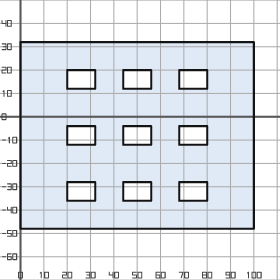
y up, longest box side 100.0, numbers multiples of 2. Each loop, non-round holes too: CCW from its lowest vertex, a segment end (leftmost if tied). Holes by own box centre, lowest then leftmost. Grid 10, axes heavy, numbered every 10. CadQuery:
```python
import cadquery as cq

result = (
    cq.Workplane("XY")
    .moveTo(0.0, -48.0)
    .lineTo(100.0, -48.0)
    .lineTo(100.0, 32.0)
    .lineTo(0.0, 32.0)
    .close()
    .moveTo(20.0, -36.0)
    .lineTo(32.0, -36.0)
    .lineTo(32.0, -28.0)
    .lineTo(20.0, -28.0)
    .close()
    .moveTo(44.0, -36.0)
    .lineTo(56.0, -36.0)
    .lineTo(56.0, -28.0)
    .lineTo(44.0, -28.0)
    .close()
    .moveTo(68.0, -36.0)
    .lineTo(80.0, -36.0)
    .lineTo(80.0, -28.0)
    .lineTo(68.0, -28.0)
    .close()
    .moveTo(20.0, -12.0)
    .lineTo(32.0, -12.0)
    .lineTo(32.0, -4.0)
    .lineTo(20.0, -4.0)
    .close()
    .moveTo(44.0, -12.0)
    .lineTo(56.0, -12.0)
    .lineTo(56.0, -4.0)
    .lineTo(44.0, -4.0)
    .close()
    .moveTo(68.0, -12.0)
    .lineTo(80.0, -12.0)
    .lineTo(80.0, -4.0)
    .lineTo(68.0, -4.0)
    .close()
    .moveTo(20.0, 12.0)
    .lineTo(32.0, 12.0)
    .lineTo(32.0, 20.0)
    .lineTo(20.0, 20.0)
    .close()
    .moveTo(44.0, 12.0)
    .lineTo(56.0, 12.0)
    .lineTo(56.0, 20.0)
    .lineTo(44.0, 20.0)
    .close()
    .moveTo(68.0, 12.0)
    .lineTo(80.0, 12.0)
    .lineTo(80.0, 20.0)
    .lineTo(68.0, 20.0)
    .close()
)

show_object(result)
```